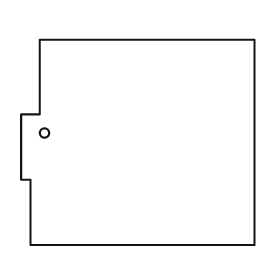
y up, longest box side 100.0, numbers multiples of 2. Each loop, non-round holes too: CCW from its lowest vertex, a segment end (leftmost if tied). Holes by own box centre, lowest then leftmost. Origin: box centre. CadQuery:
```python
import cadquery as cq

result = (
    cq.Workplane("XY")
    .moveTo(-46.0, -44.0)
    .lineTo(50.0, -44.0)
    .lineTo(50.0, 44.0)
    .lineTo(-42.0, 44.0)
    .lineTo(-42.0, 12.0)
    .lineTo(-50.0, 12.0)
    .lineTo(-50.0, -16.0)
    .lineTo(-46.0, -16.0)
    .close()
    .moveTo(-40.0, 4.0)
    .circle(2.0)
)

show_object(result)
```